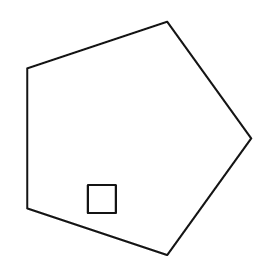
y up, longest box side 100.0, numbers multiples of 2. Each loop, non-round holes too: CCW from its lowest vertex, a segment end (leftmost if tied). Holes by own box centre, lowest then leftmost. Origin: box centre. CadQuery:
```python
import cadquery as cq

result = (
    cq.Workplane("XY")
    .moveTo(12.0, -50.0)
    .lineTo(48.0, 0.0)
    .lineTo(12.0, 50.0)
    .lineTo(-48.0, 30.0)
    .lineTo(-48.0, -30.0)
    .close()
    .moveTo(-22.0, -32.0)
    .lineTo(-10.0, -32.0)
    .lineTo(-10.0, -20.0)
    .lineTo(-22.0, -20.0)
    .close()
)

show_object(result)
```